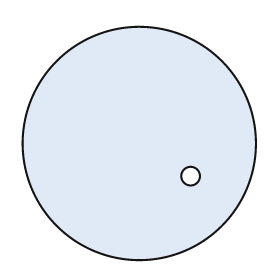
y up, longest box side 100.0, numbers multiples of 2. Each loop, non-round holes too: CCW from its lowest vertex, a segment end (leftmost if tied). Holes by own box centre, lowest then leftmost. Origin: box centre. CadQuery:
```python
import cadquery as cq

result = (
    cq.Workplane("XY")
    .moveTo(0.0, 0.0)
    .circle(50.0)
    .moveTo(22.0, -14.0)
    .circle(4.0)
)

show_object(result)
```